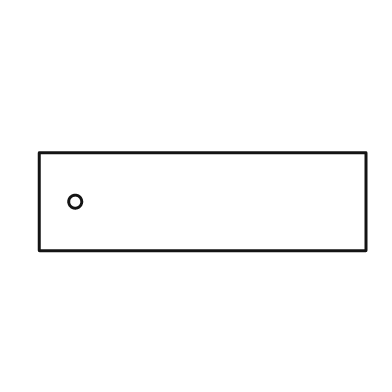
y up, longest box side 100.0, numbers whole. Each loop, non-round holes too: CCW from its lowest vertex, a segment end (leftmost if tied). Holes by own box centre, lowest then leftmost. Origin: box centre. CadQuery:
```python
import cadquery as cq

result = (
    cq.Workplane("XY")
    .moveTo(-50.0, -15.0)
    .lineTo(50.0, -15.0)
    .lineTo(50.0, 15.0)
    .lineTo(-50.0, 15.0)
    .close()
    .moveTo(-39.0, 0.0)
    .circle(2.0)
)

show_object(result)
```